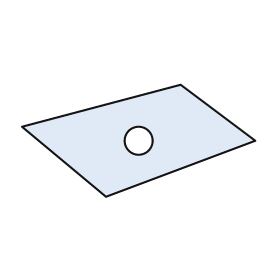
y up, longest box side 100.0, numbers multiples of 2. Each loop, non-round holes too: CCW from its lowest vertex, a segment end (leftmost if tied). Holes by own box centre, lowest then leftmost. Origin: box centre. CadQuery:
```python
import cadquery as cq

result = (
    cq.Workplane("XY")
    .moveTo(-14.0, -24.0)
    .lineTo(50.0, 0.0)
    .lineTo(18.0, 24.0)
    .lineTo(-50.0, 6.0)
    .close()
    .moveTo(0.0, 0.0)
    .circle(6.0)
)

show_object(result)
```